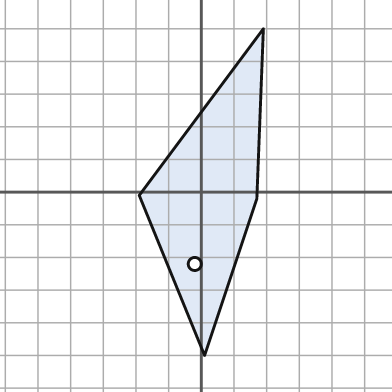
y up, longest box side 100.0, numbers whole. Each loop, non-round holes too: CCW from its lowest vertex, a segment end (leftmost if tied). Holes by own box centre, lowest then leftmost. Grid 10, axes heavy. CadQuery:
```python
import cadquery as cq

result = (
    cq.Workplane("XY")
    .moveTo(1.0, -50.0)
    .lineTo(17.0, -2.0)
    .lineTo(19.0, 50.0)
    .lineTo(-19.0, -1.0)
    .close()
    .moveTo(-2.0, -22.0)
    .circle(2.0)
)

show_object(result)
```